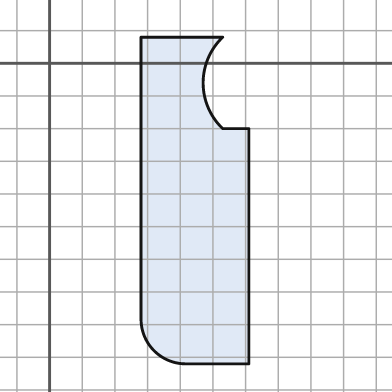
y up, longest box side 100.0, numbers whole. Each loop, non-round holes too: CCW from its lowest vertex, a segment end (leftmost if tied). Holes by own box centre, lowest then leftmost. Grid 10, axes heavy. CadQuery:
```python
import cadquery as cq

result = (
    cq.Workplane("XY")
    .moveTo(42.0, -92.0)
    .lineTo(61.0, -92.0)
    .lineTo(61.0, -20.0)
    .lineTo(53.0, -20.0)
    .threePointArc((47.0, -6.0), (53.0, 8.0))
    .lineTo(28.0, 8.0)
    .lineTo(28.0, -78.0)
    .threePointArc((32.0, -88.0), (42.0, -92.0))
    .close()
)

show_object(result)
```